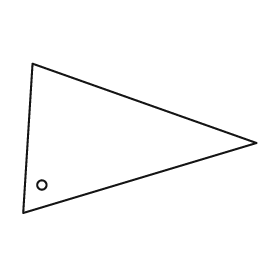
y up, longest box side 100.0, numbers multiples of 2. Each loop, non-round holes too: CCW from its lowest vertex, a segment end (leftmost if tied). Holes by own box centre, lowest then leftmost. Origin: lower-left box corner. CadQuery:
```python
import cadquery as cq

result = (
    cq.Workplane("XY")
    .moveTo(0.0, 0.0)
    .lineTo(100.0, 30.0)
    .lineTo(4.0, 64.0)
    .close()
    .moveTo(8.0, 12.0)
    .circle(2.0)
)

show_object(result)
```